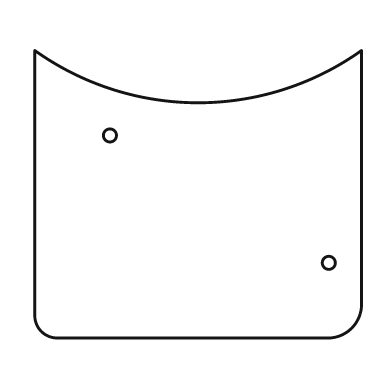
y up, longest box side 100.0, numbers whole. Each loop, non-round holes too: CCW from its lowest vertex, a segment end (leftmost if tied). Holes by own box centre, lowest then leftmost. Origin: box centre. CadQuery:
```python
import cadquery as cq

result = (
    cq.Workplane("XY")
    .moveTo(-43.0, -44.0)
    .lineTo(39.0, -44.0)
    .threePointArc((47.0, -41.0), (50.0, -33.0))
    .lineTo(50.0, 44.0)
    .threePointArc((0.0, 28.0), (-50.0, 44.0))
    .lineTo(-50.0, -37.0)
    .threePointArc((-48.0, -42.0), (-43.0, -44.0))
    .close()
    .moveTo(40.0, -21.0)
    .circle(2.0)
    .moveTo(-27.0, 18.0)
    .circle(2.0)
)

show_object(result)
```